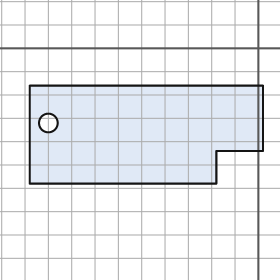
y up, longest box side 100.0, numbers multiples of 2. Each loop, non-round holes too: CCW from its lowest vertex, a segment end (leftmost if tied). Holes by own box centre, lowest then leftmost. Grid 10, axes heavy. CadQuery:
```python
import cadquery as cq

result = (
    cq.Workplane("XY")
    .moveTo(-98.0, -58.0)
    .lineTo(-18.0, -58.0)
    .lineTo(-18.0, -44.0)
    .lineTo(2.0, -44.0)
    .lineTo(2.0, -16.0)
    .lineTo(-98.0, -16.0)
    .close()
    .moveTo(-90.0, -32.0)
    .circle(4.0)
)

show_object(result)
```